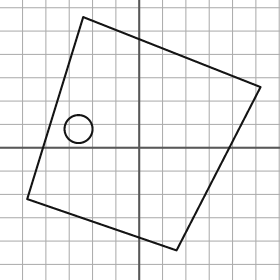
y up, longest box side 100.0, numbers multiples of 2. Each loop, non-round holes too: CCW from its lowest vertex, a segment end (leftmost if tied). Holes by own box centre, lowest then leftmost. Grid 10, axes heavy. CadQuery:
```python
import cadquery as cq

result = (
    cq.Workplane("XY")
    .moveTo(16.0, -44.0)
    .lineTo(52.0, 26.0)
    .lineTo(-24.0, 56.0)
    .lineTo(-48.0, -22.0)
    .close()
    .moveTo(-26.0, 8.0)
    .circle(6.0)
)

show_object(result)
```